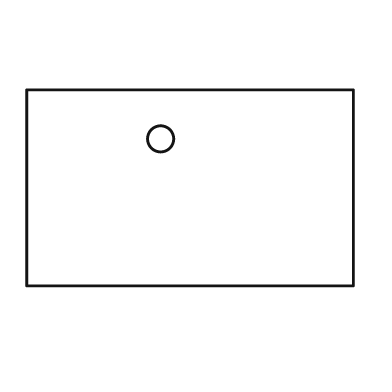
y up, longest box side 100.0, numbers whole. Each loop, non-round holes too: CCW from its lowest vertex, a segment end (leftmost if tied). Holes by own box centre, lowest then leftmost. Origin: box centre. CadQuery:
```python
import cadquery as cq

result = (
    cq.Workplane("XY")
    .moveTo(-50.0, -30.0)
    .lineTo(50.0, -30.0)
    .lineTo(50.0, 30.0)
    .lineTo(-50.0, 30.0)
    .close()
    .moveTo(-9.0, 15.0)
    .circle(4.0)
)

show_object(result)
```